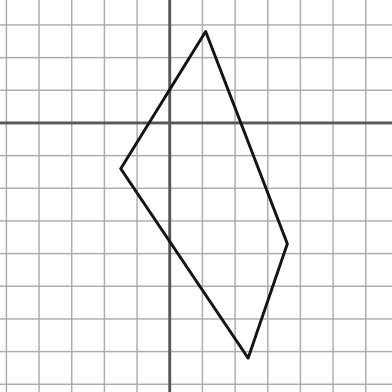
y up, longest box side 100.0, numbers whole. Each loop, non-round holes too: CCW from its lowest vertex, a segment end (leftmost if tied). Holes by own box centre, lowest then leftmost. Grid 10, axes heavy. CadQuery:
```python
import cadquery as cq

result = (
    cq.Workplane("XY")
    .moveTo(24.0, -72.0)
    .lineTo(36.0, -37.0)
    .lineTo(11.0, 28.0)
    .lineTo(-15.0, -14.0)
    .close()
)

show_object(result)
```